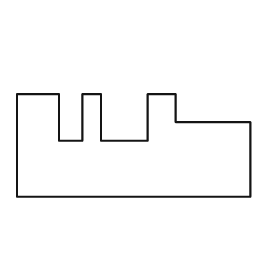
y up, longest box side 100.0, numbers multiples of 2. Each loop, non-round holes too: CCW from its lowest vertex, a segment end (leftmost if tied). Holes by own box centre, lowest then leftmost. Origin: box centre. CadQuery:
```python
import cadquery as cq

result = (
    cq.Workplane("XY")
    .moveTo(-50.0, -22.0)
    .lineTo(50.0, -22.0)
    .lineTo(50.0, 10.0)
    .lineTo(18.0, 10.0)
    .lineTo(18.0, 22.0)
    .lineTo(6.0, 22.0)
    .lineTo(6.0, 2.0)
    .lineTo(-14.0, 2.0)
    .lineTo(-14.0, 22.0)
    .lineTo(-22.0, 22.0)
    .lineTo(-22.0, 2.0)
    .lineTo(-32.0, 2.0)
    .lineTo(-32.0, 22.0)
    .lineTo(-50.0, 22.0)
    .close()
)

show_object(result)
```